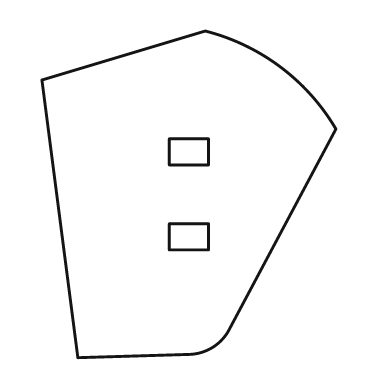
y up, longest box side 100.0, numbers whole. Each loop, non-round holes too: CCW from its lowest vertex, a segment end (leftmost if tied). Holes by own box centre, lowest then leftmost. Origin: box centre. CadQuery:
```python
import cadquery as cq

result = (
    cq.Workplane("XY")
    .moveTo(-34.0, -50.0)
    .lineTo(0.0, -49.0)
    .threePointArc((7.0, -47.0), (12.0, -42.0))
    .lineTo(45.0, 20.0)
    .threePointArc((28.0, 39.0), (5.0, 50.0))
    .lineTo(-45.0, 35.0)
    .close()
    .moveTo(-6.0, -17.0)
    .lineTo(6.0, -17.0)
    .lineTo(6.0, -9.0)
    .lineTo(-6.0, -9.0)
    .close()
    .moveTo(-6.0, 9.0)
    .lineTo(6.0, 9.0)
    .lineTo(6.0, 17.0)
    .lineTo(-6.0, 17.0)
    .close()
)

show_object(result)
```